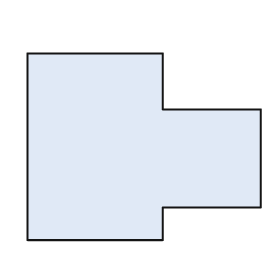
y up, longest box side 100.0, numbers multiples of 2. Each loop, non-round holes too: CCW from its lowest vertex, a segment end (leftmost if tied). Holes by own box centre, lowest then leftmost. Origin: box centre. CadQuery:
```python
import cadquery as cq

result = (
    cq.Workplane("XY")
    .moveTo(-50.0, -40.0)
    .lineTo(8.0, -40.0)
    .lineTo(8.0, -26.0)
    .lineTo(50.0, -26.0)
    .lineTo(50.0, 16.0)
    .lineTo(8.0, 16.0)
    .lineTo(8.0, 40.0)
    .lineTo(-50.0, 40.0)
    .close()
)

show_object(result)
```